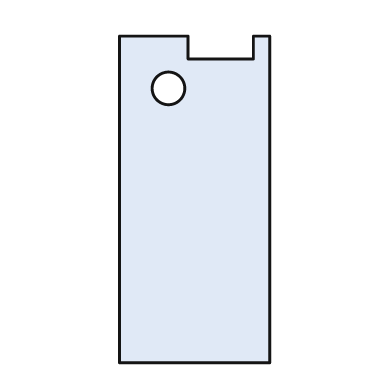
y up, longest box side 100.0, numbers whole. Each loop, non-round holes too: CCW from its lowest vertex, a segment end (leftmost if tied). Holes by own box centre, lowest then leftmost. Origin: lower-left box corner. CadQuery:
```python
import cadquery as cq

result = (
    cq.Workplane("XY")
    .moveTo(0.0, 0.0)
    .lineTo(46.0, 0.0)
    .lineTo(46.0, 100.0)
    .lineTo(41.0, 100.0)
    .lineTo(41.0, 93.0)
    .lineTo(21.0, 93.0)
    .lineTo(21.0, 100.0)
    .lineTo(0.0, 100.0)
    .close()
    .moveTo(15.0, 84.0)
    .circle(5.0)
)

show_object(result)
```